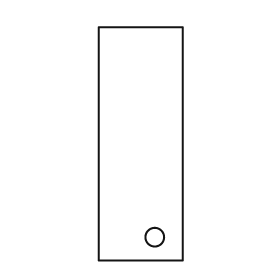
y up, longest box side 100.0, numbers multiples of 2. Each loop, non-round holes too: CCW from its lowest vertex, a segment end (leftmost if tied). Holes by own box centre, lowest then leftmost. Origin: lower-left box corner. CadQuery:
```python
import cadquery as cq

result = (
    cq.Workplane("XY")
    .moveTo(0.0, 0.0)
    .lineTo(36.0, 0.0)
    .lineTo(36.0, 100.0)
    .lineTo(0.0, 100.0)
    .close()
    .moveTo(24.0, 10.0)
    .circle(4.0)
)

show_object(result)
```